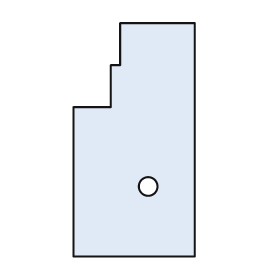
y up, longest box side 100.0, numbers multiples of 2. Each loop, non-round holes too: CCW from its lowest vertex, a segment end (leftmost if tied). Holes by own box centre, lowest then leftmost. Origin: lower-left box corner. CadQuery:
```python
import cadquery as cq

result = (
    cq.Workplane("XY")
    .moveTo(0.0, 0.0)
    .lineTo(52.0, 0.0)
    .lineTo(52.0, 100.0)
    .lineTo(20.0, 100.0)
    .lineTo(20.0, 82.0)
    .lineTo(16.0, 82.0)
    .lineTo(16.0, 64.0)
    .lineTo(0.0, 64.0)
    .close()
    .moveTo(32.0, 30.0)
    .circle(4.0)
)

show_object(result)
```